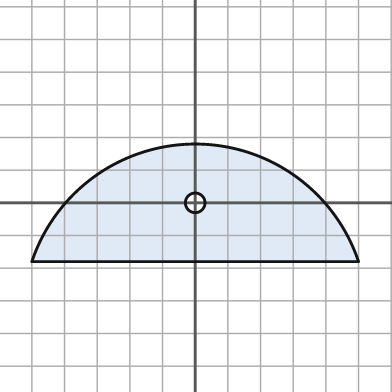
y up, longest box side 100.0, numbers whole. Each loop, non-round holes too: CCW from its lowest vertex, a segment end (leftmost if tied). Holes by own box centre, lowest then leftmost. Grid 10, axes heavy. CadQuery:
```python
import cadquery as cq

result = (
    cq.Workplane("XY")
    .moveTo(-50.0, -18.0)
    .lineTo(50.0, -18.0)
    .threePointArc((0.0, 18.0), (-50.0, -18.0))
    .close()
    .moveTo(0.0, 0.0)
    .circle(3.0)
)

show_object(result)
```